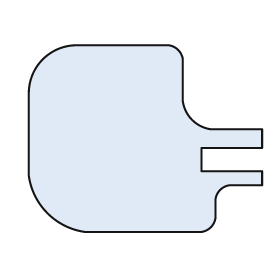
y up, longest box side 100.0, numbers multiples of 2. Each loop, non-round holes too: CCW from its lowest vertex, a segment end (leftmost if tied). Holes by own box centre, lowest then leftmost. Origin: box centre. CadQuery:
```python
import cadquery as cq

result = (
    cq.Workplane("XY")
    .moveTo(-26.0, -40.0)
    .lineTo(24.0, -40.0)
    .threePointArc((28.0, -38.0), (30.0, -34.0))
    .lineTo(30.0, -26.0)
    .threePointArc((32.0, -22.0), (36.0, -20.0))
    .lineTo(50.0, -20.0)
    .lineTo(50.0, -14.0)
    .lineTo(24.0, -14.0)
    .lineTo(24.0, -4.0)
    .lineTo(50.0, -4.0)
    .lineTo(50.0, 4.0)
    .lineTo(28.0, 4.0)
    .threePointArc((20.0, 8.0), (16.0, 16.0))
    .lineTo(16.0, 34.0)
    .threePointArc((14.0, 38.0), (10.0, 40.0))
    .lineTo(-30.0, 40.0)
    .threePointArc((-44.0, 34.0), (-50.0, 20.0))
    .lineTo(-50.0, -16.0)
    .threePointArc((-42.0, -32.0), (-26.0, -40.0))
    .close()
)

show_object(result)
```